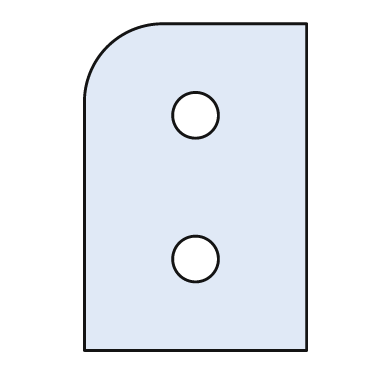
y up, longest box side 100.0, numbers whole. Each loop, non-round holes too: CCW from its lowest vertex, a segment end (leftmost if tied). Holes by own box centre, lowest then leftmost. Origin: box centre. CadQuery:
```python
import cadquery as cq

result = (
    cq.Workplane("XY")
    .moveTo(-34.0, -50.0)
    .lineTo(34.0, -50.0)
    .lineTo(34.0, 50.0)
    .lineTo(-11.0, 50.0)
    .threePointArc((-27.0, 43.0), (-34.0, 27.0))
    .close()
    .moveTo(0.0, -22.0)
    .circle(7.0)
    .moveTo(0.0, 22.0)
    .circle(7.0)
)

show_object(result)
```